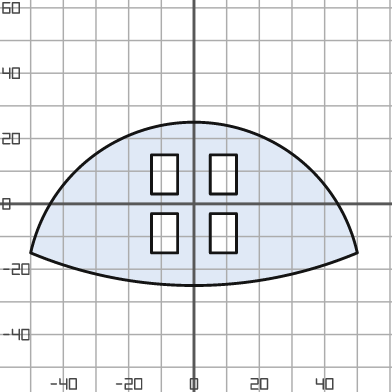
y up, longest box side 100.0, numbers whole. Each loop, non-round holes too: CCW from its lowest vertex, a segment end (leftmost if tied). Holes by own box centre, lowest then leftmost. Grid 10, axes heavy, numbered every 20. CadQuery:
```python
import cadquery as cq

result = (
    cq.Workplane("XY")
    .moveTo(-50.0, -15.0)
    .threePointArc((0.0, -25.0), (50.0, -15.0))
    .threePointArc((0.0, 25.0), (-50.0, -15.0))
    .close()
    .moveTo(-13.0, -15.0)
    .lineTo(-5.0, -15.0)
    .lineTo(-5.0, -3.0)
    .lineTo(-13.0, -3.0)
    .close()
    .moveTo(5.0, -15.0)
    .lineTo(13.0, -15.0)
    .lineTo(13.0, -3.0)
    .lineTo(5.0, -3.0)
    .close()
    .moveTo(-13.0, 3.0)
    .lineTo(-5.0, 3.0)
    .lineTo(-5.0, 15.0)
    .lineTo(-13.0, 15.0)
    .close()
    .moveTo(5.0, 3.0)
    .lineTo(13.0, 3.0)
    .lineTo(13.0, 15.0)
    .lineTo(5.0, 15.0)
    .close()
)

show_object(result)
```